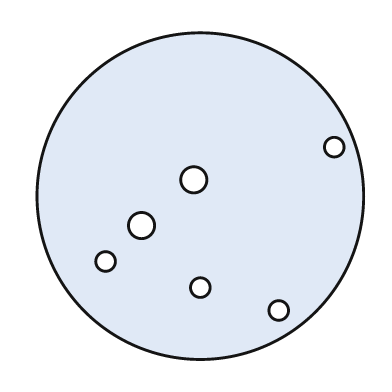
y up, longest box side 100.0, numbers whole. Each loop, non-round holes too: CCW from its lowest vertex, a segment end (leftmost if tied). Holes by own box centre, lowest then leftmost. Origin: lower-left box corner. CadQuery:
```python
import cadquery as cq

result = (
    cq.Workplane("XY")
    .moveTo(50.0, 50.0)
    .circle(50.0)
    .moveTo(74.0, 15.0)
    .circle(3.0)
    .moveTo(50.0, 22.0)
    .circle(3.0)
    .moveTo(21.0, 30.0)
    .circle(3.0)
    .moveTo(32.0, 41.0)
    .circle(4.0)
    .moveTo(48.0, 55.0)
    .circle(4.0)
    .moveTo(91.0, 65.0)
    .circle(3.0)
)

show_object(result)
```